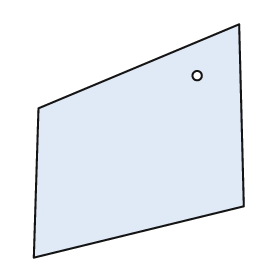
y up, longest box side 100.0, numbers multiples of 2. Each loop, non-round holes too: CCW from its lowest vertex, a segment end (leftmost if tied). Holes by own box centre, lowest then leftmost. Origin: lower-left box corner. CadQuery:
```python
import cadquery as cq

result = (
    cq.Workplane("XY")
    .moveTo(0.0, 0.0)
    .lineTo(90.0, 22.0)
    .lineTo(88.0, 100.0)
    .lineTo(2.0, 64.0)
    .close()
    .moveTo(70.0, 78.0)
    .circle(2.0)
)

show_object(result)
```